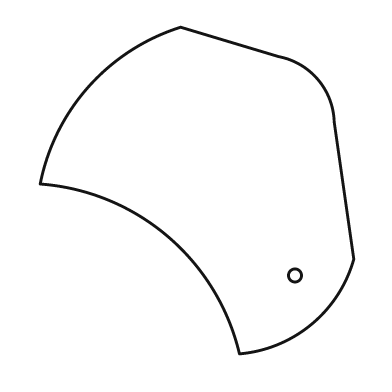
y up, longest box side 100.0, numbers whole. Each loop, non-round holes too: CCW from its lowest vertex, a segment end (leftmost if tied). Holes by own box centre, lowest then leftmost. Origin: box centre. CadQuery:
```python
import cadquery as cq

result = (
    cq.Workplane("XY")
    .moveTo(13.0, -50.0)
    .threePointArc((35.0, -41.0), (48.0, -21.0))
    .lineTo(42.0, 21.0)
    .threePointArc((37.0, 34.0), (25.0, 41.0))
    .lineTo(-5.0, 50.0)
    .threePointArc((-33.0, 32.0), (-48.0, 2.0))
    .threePointArc((-9.0, -14.0), (13.0, -50.0))
    .close()
    .moveTo(30.0, -26.0)
    .circle(2.0)
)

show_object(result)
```